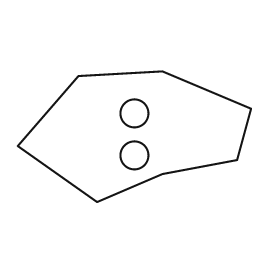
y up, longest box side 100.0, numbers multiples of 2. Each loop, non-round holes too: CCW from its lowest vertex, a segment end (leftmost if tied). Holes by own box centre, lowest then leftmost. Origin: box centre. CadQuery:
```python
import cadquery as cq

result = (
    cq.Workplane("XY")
    .moveTo(-16.0, -28.0)
    .lineTo(12.0, -16.0)
    .lineTo(44.0, -10.0)
    .lineTo(50.0, 12.0)
    .lineTo(12.0, 28.0)
    .lineTo(-24.0, 26.0)
    .lineTo(-50.0, -4.0)
    .close()
    .moveTo(0.0, -8.0)
    .circle(6.0)
    .moveTo(0.0, 10.0)
    .circle(6.0)
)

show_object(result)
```